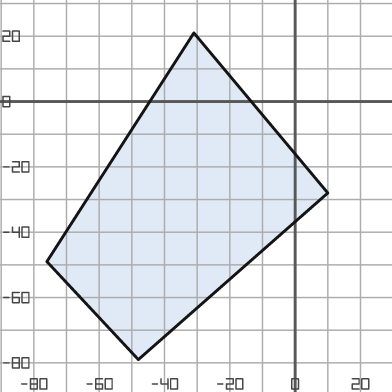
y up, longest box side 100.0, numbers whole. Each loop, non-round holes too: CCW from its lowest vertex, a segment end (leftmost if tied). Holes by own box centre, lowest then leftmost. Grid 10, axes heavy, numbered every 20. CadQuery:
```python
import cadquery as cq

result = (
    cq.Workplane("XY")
    .moveTo(-48.0, -79.0)
    .lineTo(10.0, -28.0)
    .lineTo(-31.0, 21.0)
    .lineTo(-76.0, -49.0)
    .close()
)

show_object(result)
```